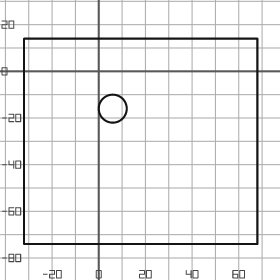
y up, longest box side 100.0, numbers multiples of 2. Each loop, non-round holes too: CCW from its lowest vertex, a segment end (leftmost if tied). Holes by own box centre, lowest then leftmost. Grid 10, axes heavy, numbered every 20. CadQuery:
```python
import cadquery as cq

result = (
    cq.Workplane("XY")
    .moveTo(-32.0, -74.0)
    .lineTo(68.0, -74.0)
    .lineTo(68.0, 14.0)
    .lineTo(-32.0, 14.0)
    .close()
    .moveTo(6.0, -16.0)
    .circle(6.0)
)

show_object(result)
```